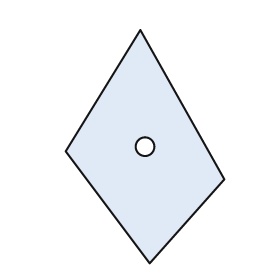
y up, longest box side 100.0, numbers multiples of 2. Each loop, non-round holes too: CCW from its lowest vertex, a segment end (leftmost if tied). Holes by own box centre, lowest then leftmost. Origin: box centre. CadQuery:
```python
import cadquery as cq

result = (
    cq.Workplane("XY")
    .moveTo(2.0, -50.0)
    .lineTo(34.0, -14.0)
    .lineTo(-2.0, 50.0)
    .lineTo(-34.0, -2.0)
    .close()
    .moveTo(0.0, 0.0)
    .circle(4.0)
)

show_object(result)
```